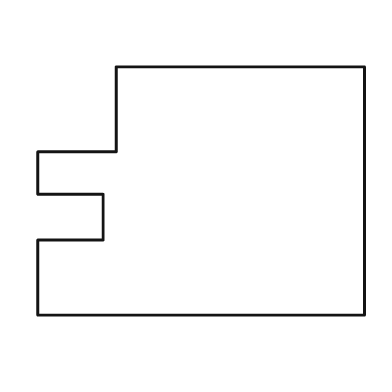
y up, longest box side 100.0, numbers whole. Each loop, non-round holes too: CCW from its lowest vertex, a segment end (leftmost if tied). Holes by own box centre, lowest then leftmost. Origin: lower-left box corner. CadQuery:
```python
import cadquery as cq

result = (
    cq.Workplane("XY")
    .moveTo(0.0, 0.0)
    .lineTo(100.0, 0.0)
    .lineTo(100.0, 76.0)
    .lineTo(24.0, 76.0)
    .lineTo(24.0, 50.0)
    .lineTo(0.0, 50.0)
    .lineTo(0.0, 37.0)
    .lineTo(20.0, 37.0)
    .lineTo(20.0, 23.0)
    .lineTo(0.0, 23.0)
    .close()
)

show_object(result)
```